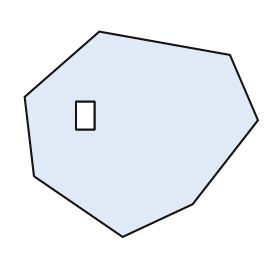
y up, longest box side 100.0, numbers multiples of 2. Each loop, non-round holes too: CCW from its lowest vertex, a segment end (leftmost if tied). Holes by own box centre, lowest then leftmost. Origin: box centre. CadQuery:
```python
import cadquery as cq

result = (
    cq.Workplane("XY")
    .moveTo(-8.0, -44.0)
    .lineTo(22.0, -30.0)
    .lineTo(50.0, 6.0)
    .lineTo(38.0, 34.0)
    .lineTo(-18.0, 44.0)
    .lineTo(-50.0, 16.0)
    .lineTo(-46.0, -18.0)
    .close()
    .moveTo(-28.0, 2.0)
    .lineTo(-20.0, 2.0)
    .lineTo(-20.0, 14.0)
    .lineTo(-28.0, 14.0)
    .close()
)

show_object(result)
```